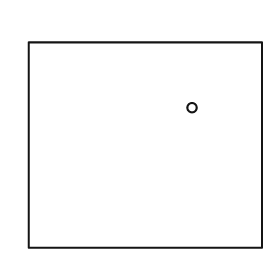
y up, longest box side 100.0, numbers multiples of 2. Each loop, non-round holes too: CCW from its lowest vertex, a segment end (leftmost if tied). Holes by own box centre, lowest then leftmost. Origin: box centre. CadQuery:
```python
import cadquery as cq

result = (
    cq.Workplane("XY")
    .moveTo(-50.0, -44.0)
    .lineTo(50.0, -44.0)
    .lineTo(50.0, 44.0)
    .lineTo(-50.0, 44.0)
    .close()
    .moveTo(20.0, 16.0)
    .circle(2.0)
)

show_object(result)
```